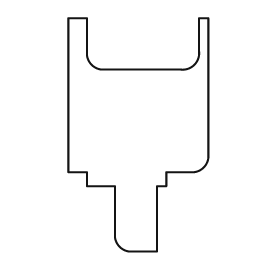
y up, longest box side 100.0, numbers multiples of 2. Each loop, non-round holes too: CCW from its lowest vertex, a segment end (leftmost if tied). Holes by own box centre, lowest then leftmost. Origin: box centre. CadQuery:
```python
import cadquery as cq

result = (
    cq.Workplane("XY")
    .moveTo(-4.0, -50.0)
    .lineTo(8.0, -50.0)
    .lineTo(8.0, -22.0)
    .lineTo(12.0, -22.0)
    .lineTo(12.0, -16.0)
    .lineTo(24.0, -16.0)
    .threePointArc((28.0, -14.0), (30.0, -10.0))
    .lineTo(30.0, 50.0)
    .lineTo(26.0, 50.0)
    .lineTo(26.0, 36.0)
    .threePointArc((24.0, 30.0), (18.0, 28.0))
    .lineTo(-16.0, 28.0)
    .threePointArc((-20.0, 30.0), (-22.0, 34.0))
    .lineTo(-22.0, 50.0)
    .lineTo(-30.0, 50.0)
    .lineTo(-30.0, -16.0)
    .lineTo(-22.0, -16.0)
    .lineTo(-22.0, -22.0)
    .lineTo(-10.0, -22.0)
    .lineTo(-10.0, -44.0)
    .threePointArc((-8.0, -48.0), (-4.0, -50.0))
    .close()
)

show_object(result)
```